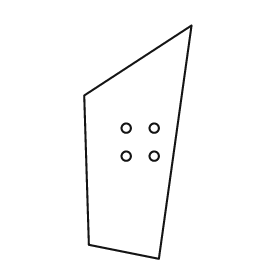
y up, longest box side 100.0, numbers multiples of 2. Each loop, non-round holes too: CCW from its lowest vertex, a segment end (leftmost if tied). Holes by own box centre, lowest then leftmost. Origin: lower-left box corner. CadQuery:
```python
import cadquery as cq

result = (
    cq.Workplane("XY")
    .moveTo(32.0, 0.0)
    .lineTo(46.0, 100.0)
    .lineTo(0.0, 70.0)
    .lineTo(2.0, 6.0)
    .close()
    .moveTo(18.0, 44.0)
    .circle(2.0)
    .moveTo(30.0, 44.0)
    .circle(2.0)
    .moveTo(18.0, 56.0)
    .circle(2.0)
    .moveTo(30.0, 56.0)
    .circle(2.0)
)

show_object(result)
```